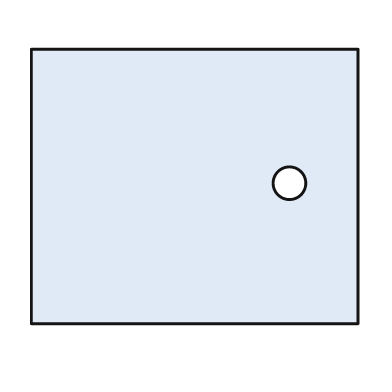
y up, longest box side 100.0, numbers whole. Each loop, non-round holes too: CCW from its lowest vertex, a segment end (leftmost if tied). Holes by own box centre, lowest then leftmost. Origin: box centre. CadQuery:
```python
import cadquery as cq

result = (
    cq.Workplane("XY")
    .moveTo(-50.0, -42.0)
    .lineTo(50.0, -42.0)
    .lineTo(50.0, 42.0)
    .lineTo(-50.0, 42.0)
    .close()
    .moveTo(29.0, 1.0)
    .circle(5.0)
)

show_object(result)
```